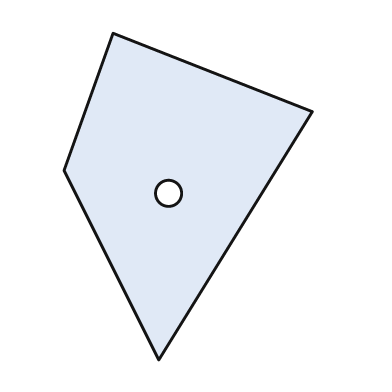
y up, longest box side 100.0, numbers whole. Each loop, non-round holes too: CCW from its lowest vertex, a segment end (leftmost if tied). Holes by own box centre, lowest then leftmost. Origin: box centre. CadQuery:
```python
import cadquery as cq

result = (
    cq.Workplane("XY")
    .moveTo(-9.0, -50.0)
    .lineTo(38.0, 26.0)
    .lineTo(-23.0, 50.0)
    .lineTo(-38.0, 8.0)
    .close()
    .moveTo(-6.0, 1.0)
    .circle(4.0)
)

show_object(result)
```